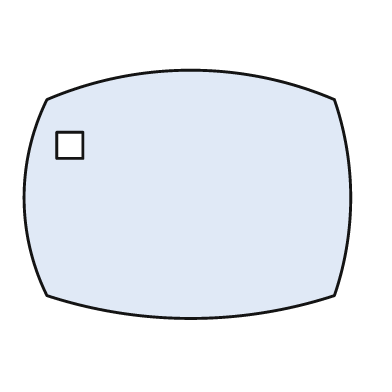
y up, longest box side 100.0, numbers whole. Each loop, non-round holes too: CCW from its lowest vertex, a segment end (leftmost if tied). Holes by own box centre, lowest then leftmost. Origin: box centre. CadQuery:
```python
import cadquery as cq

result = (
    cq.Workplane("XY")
    .moveTo(-43.0, -31.0)
    .threePointArc((1.0, -38.0), (45.0, -31.0))
    .threePointArc((50.0, -1.0), (45.0, 29.0))
    .threePointArc((1.0, 38.0), (-43.0, 29.0))
    .threePointArc((-50.0, -1.0), (-43.0, -31.0))
    .close()
    .moveTo(-40.0, 11.0)
    .lineTo(-32.0, 11.0)
    .lineTo(-32.0, 19.0)
    .lineTo(-40.0, 19.0)
    .close()
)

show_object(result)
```